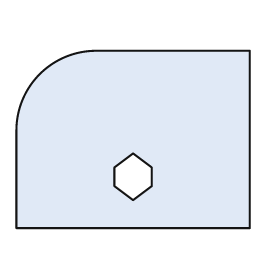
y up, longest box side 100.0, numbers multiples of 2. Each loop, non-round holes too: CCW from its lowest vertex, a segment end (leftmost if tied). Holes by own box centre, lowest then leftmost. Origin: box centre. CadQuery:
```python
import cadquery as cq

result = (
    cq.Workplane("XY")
    .moveTo(-50.0, -38.0)
    .lineTo(50.0, -38.0)
    .lineTo(50.0, 38.0)
    .lineTo(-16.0, 38.0)
    .threePointArc((-40.0, 28.0), (-50.0, 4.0))
    .close()
    .moveTo(0.0, -26.0)
    .lineTo(8.0, -20.0)
    .lineTo(8.0, -12.0)
    .lineTo(0.0, -6.0)
    .lineTo(-8.0, -12.0)
    .lineTo(-8.0, -20.0)
    .close()
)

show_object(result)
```